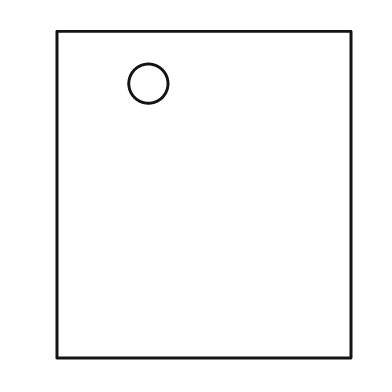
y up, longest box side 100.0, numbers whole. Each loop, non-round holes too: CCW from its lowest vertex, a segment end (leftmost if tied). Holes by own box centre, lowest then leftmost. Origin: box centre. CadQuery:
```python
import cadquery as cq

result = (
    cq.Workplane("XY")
    .moveTo(-45.0, -50.0)
    .lineTo(45.0, -50.0)
    .lineTo(45.0, 50.0)
    .lineTo(-45.0, 50.0)
    .close()
    .moveTo(-17.0, 34.0)
    .circle(6.0)
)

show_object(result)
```